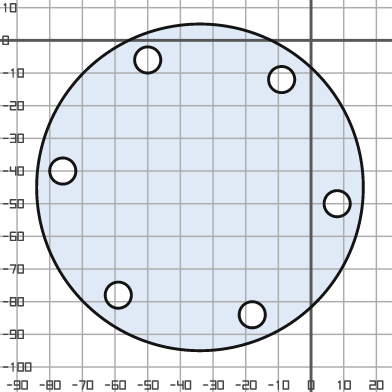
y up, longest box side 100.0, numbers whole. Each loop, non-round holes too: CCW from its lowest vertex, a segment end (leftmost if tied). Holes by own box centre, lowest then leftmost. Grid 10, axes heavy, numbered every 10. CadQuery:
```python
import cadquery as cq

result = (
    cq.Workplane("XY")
    .moveTo(-34.0, -45.0)
    .circle(50.0)
    .moveTo(-18.0, -84.0)
    .circle(4.0)
    .moveTo(-59.0, -78.0)
    .circle(4.0)
    .moveTo(8.0, -50.0)
    .circle(4.0)
    .moveTo(-76.0, -40.0)
    .circle(4.0)
    .moveTo(-9.0, -12.0)
    .circle(4.0)
    .moveTo(-50.0, -6.0)
    .circle(4.0)
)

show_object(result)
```